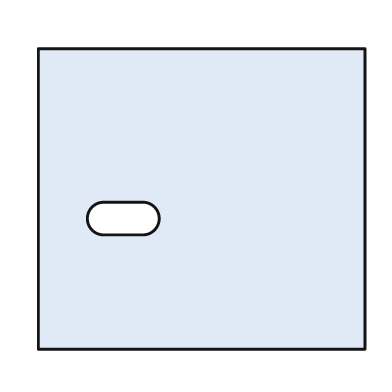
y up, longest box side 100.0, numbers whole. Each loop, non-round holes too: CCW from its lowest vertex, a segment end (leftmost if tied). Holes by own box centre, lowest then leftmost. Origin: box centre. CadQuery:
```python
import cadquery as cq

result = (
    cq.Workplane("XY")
    .moveTo(-50.0, -46.0)
    .lineTo(50.0, -46.0)
    .lineTo(50.0, 46.0)
    .lineTo(-50.0, 46.0)
    .close()
    .moveTo(-30.0, -11.0)
    .lineTo(-18.0, -11.0)
    .threePointArc((-13.0, -6.0), (-18.0, -1.0))
    .lineTo(-30.0, -1.0)
    .threePointArc((-35.0, -6.0), (-30.0, -11.0))
    .close()
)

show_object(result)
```